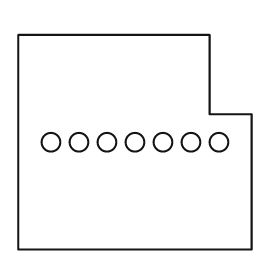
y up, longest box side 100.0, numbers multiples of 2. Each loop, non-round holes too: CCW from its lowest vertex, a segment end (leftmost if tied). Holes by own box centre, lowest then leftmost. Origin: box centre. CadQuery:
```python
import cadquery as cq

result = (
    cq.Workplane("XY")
    .moveTo(-50.0, -46.0)
    .lineTo(50.0, -46.0)
    .lineTo(50.0, 12.0)
    .lineTo(32.0, 12.0)
    .lineTo(32.0, 46.0)
    .lineTo(-50.0, 46.0)
    .close()
    .moveTo(-36.0, 0.0)
    .circle(4.0)
    .moveTo(-24.0, 0.0)
    .circle(4.0)
    .moveTo(-12.0, 0.0)
    .circle(4.0)
    .moveTo(0.0, 0.0)
    .circle(4.0)
    .moveTo(12.0, 0.0)
    .circle(4.0)
    .moveTo(24.0, 0.0)
    .circle(4.0)
    .moveTo(36.0, 0.0)
    .circle(4.0)
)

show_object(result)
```